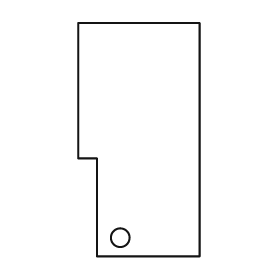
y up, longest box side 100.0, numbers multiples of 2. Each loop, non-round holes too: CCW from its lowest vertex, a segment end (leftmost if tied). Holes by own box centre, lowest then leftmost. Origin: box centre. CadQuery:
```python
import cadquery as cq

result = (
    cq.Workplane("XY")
    .moveTo(-18.0, -50.0)
    .lineTo(26.0, -50.0)
    .lineTo(26.0, 50.0)
    .lineTo(-26.0, 50.0)
    .lineTo(-26.0, -8.0)
    .lineTo(-18.0, -8.0)
    .close()
    .moveTo(-8.0, -42.0)
    .circle(4.0)
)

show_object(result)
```